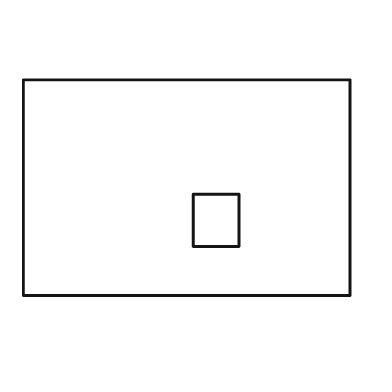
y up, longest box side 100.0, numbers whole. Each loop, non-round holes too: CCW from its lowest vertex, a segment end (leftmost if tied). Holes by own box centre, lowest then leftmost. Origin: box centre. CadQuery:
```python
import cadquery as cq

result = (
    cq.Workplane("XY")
    .moveTo(-50.0, -33.0)
    .lineTo(50.0, -33.0)
    .lineTo(50.0, 33.0)
    .lineTo(-50.0, 33.0)
    .close()
    .moveTo(2.0, -18.0)
    .lineTo(16.0, -18.0)
    .lineTo(16.0, -2.0)
    .lineTo(2.0, -2.0)
    .close()
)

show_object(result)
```